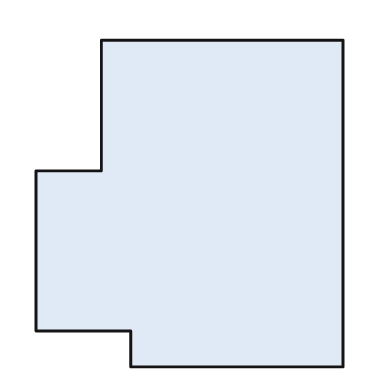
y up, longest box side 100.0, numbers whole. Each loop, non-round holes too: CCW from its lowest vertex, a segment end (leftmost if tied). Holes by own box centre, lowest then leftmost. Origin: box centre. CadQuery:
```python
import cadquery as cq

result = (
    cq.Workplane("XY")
    .moveTo(-18.0, -50.0)
    .lineTo(47.0, -50.0)
    .lineTo(47.0, 50.0)
    .lineTo(-27.0, 50.0)
    .lineTo(-27.0, 10.0)
    .lineTo(-47.0, 10.0)
    .lineTo(-47.0, -39.0)
    .lineTo(-18.0, -39.0)
    .close()
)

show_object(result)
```